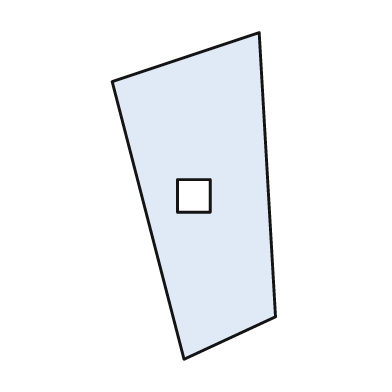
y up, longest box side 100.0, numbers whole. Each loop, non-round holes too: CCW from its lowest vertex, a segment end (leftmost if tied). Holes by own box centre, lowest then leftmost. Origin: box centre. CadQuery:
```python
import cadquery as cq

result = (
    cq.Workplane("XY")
    .moveTo(-3.0, -50.0)
    .lineTo(25.0, -37.0)
    .lineTo(20.0, 50.0)
    .lineTo(-25.0, 35.0)
    .close()
    .moveTo(-5.0, -5.0)
    .lineTo(5.0, -5.0)
    .lineTo(5.0, 5.0)
    .lineTo(-5.0, 5.0)
    .close()
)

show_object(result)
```